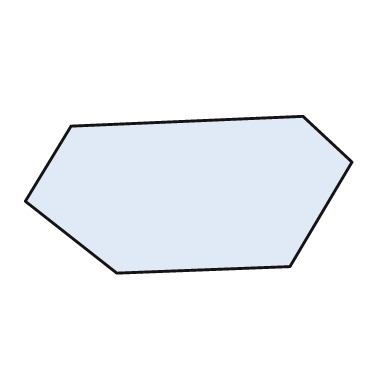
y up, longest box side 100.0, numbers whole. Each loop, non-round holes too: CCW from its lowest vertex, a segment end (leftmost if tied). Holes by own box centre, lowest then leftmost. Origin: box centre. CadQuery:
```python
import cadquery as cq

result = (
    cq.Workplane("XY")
    .moveTo(-22.0, -24.0)
    .lineTo(31.0, -22.0)
    .lineTo(50.0, 10.0)
    .lineTo(35.0, 24.0)
    .lineTo(-36.0, 21.0)
    .lineTo(-50.0, -2.0)
    .close()
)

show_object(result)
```